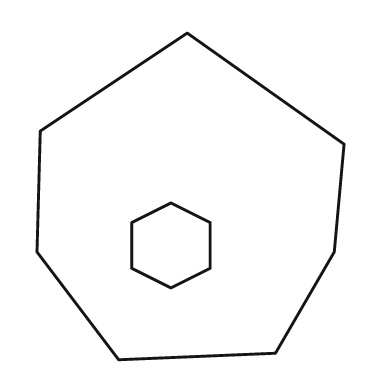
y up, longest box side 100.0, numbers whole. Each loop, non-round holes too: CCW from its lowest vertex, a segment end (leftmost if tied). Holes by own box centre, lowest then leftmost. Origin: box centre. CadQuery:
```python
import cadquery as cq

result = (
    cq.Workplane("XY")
    .moveTo(-22.0, -50.0)
    .lineTo(26.0, -48.0)
    .lineTo(44.0, -17.0)
    .lineTo(47.0, 16.0)
    .lineTo(-1.0, 50.0)
    .lineTo(-46.0, 20.0)
    .lineTo(-47.0, -17.0)
    .close()
    .moveTo(-6.0, -28.0)
    .lineTo(6.0, -22.0)
    .lineTo(6.0, -8.0)
    .lineTo(-6.0, -2.0)
    .lineTo(-18.0, -8.0)
    .lineTo(-18.0, -22.0)
    .close()
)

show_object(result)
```